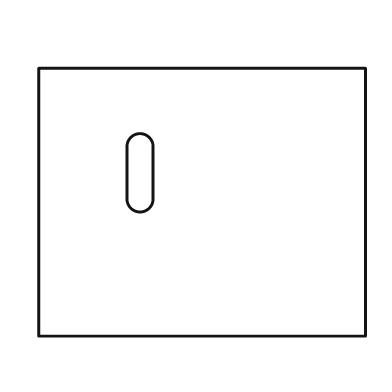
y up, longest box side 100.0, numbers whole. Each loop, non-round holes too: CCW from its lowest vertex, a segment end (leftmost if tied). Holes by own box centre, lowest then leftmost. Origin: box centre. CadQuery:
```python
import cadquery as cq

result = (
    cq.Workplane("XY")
    .moveTo(-50.0, -41.0)
    .lineTo(50.0, -41.0)
    .lineTo(50.0, 41.0)
    .lineTo(-50.0, 41.0)
    .close()
    .moveTo(-23.0, 1.0)
    .threePointArc((-19.0, -3.0), (-15.0, 1.0))
    .lineTo(-15.0, 17.0)
    .threePointArc((-19.0, 21.0), (-23.0, 17.0))
    .close()
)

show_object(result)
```